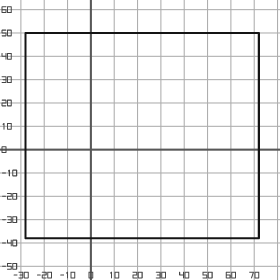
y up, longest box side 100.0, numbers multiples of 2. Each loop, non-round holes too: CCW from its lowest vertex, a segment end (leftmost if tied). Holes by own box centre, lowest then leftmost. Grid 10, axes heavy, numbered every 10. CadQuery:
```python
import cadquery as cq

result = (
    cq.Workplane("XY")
    .moveTo(-28.0, -38.0)
    .lineTo(72.0, -38.0)
    .lineTo(72.0, 50.0)
    .lineTo(-28.0, 50.0)
    .close()
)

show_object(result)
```